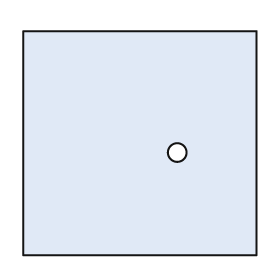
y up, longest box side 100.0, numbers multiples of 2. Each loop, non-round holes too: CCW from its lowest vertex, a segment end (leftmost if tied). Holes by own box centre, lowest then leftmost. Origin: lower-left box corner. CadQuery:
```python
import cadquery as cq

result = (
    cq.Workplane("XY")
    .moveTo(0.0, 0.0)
    .lineTo(100.0, 0.0)
    .lineTo(100.0, 96.0)
    .lineTo(0.0, 96.0)
    .close()
    .moveTo(66.0, 44.0)
    .circle(4.0)
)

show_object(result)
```